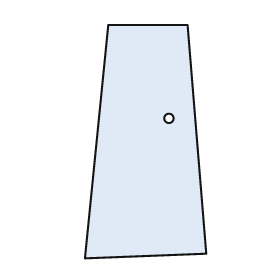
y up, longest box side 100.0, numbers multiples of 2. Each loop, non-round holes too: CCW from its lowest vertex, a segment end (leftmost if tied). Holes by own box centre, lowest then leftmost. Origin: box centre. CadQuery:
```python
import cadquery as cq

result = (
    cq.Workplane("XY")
    .moveTo(-26.0, -50.0)
    .lineTo(26.0, -48.0)
    .lineTo(18.0, 50.0)
    .lineTo(-16.0, 50.0)
    .close()
    .moveTo(10.0, 10.0)
    .circle(2.0)
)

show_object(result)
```